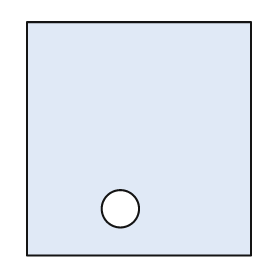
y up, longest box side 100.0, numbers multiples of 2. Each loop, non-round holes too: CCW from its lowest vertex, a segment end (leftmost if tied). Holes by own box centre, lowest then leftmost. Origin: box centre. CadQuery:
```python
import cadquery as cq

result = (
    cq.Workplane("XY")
    .moveTo(-48.0, -50.0)
    .lineTo(48.0, -50.0)
    .lineTo(48.0, 50.0)
    .lineTo(-48.0, 50.0)
    .close()
    .moveTo(-8.0, -30.0)
    .circle(8.0)
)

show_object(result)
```